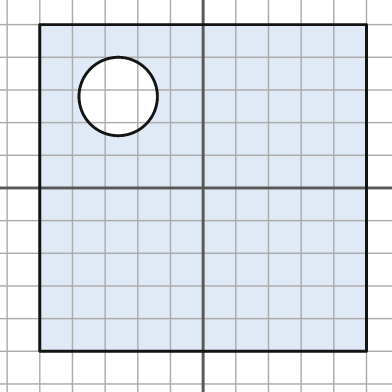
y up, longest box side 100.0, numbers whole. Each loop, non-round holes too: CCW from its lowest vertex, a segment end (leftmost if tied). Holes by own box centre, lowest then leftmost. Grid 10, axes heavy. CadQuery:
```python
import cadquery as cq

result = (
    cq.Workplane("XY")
    .moveTo(-50.0, -50.0)
    .lineTo(50.0, -50.0)
    .lineTo(50.0, 50.0)
    .lineTo(-50.0, 50.0)
    .close()
    .moveTo(-26.0, 28.0)
    .circle(12.0)
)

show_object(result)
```